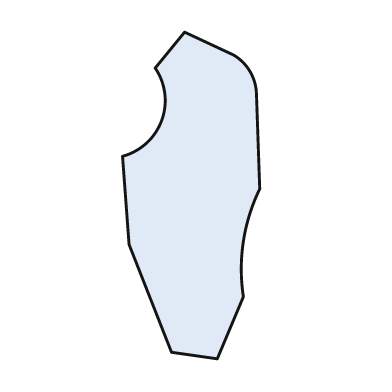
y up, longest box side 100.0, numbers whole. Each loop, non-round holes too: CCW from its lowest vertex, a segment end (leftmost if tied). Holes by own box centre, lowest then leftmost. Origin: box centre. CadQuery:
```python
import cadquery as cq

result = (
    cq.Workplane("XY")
    .moveTo(8.0, -50.0)
    .lineTo(16.0, -31.0)
    .threePointArc((16.0, -14.0), (21.0, 2.0))
    .lineTo(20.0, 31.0)
    .threePointArc((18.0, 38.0), (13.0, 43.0))
    .lineTo(-2.0, 50.0)
    .lineTo(-11.0, 39.0)
    .threePointArc((-9.0, 23.0), (-21.0, 12.0))
    .lineTo(-19.0, -15.0)
    .lineTo(-6.0, -48.0)
    .close()
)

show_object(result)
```